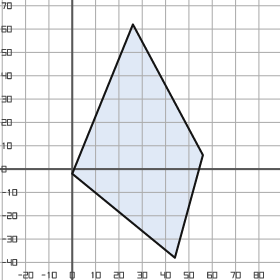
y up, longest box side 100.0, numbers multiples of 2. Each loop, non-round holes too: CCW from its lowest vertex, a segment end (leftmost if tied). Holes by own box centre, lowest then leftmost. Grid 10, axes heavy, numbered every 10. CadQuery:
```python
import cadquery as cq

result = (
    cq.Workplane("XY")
    .moveTo(44.0, -38.0)
    .lineTo(56.0, 6.0)
    .lineTo(26.0, 62.0)
    .lineTo(0.0, -2.0)
    .close()
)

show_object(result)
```